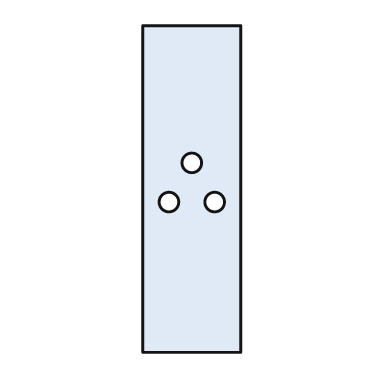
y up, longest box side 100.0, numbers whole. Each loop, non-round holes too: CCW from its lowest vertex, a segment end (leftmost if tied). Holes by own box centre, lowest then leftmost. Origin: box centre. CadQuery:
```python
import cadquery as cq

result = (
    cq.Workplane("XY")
    .moveTo(-15.0, -50.0)
    .lineTo(15.0, -50.0)
    .lineTo(15.0, 50.0)
    .lineTo(-15.0, 50.0)
    .close()
    .moveTo(-7.0, -4.0)
    .circle(3.0)
    .moveTo(7.0, -4.0)
    .circle(3.0)
    .moveTo(0.0, 8.0)
    .circle(3.0)
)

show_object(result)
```